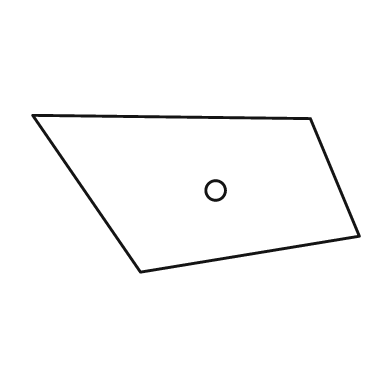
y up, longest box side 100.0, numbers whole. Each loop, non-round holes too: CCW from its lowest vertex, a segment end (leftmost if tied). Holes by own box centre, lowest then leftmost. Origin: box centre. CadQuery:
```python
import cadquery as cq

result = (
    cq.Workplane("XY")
    .moveTo(-17.0, -24.0)
    .lineTo(50.0, -13.0)
    .lineTo(35.0, 23.0)
    .lineTo(-50.0, 24.0)
    .close()
    .moveTo(6.0, 1.0)
    .circle(3.0)
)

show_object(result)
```